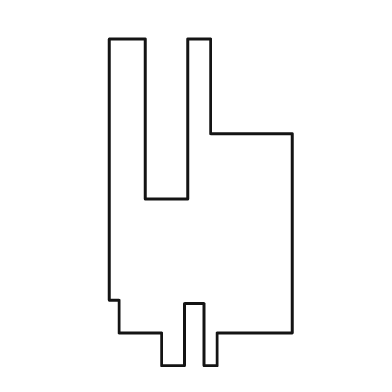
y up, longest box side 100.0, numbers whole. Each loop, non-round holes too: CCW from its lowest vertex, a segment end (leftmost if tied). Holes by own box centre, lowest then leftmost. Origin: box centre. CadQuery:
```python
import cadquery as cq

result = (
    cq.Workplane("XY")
    .moveTo(-12.0, -50.0)
    .lineTo(-5.0, -50.0)
    .lineTo(-5.0, -31.0)
    .lineTo(1.0, -31.0)
    .lineTo(1.0, -50.0)
    .lineTo(5.0, -50.0)
    .lineTo(5.0, -40.0)
    .lineTo(28.0, -40.0)
    .lineTo(28.0, 21.0)
    .lineTo(3.0, 21.0)
    .lineTo(3.0, 50.0)
    .lineTo(-4.0, 50.0)
    .lineTo(-4.0, 1.0)
    .lineTo(-17.0, 1.0)
    .lineTo(-17.0, 50.0)
    .lineTo(-28.0, 50.0)
    .lineTo(-28.0, -30.0)
    .lineTo(-25.0, -30.0)
    .lineTo(-25.0, -40.0)
    .lineTo(-12.0, -40.0)
    .close()
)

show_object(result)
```